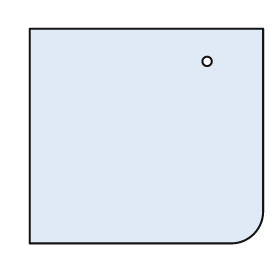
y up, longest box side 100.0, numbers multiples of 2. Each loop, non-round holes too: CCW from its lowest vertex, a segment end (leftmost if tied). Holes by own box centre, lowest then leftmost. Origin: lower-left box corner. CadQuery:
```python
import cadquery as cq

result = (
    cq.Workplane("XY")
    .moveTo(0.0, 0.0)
    .lineTo(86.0, 0.0)
    .threePointArc((96.0, 4.0), (100.0, 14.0))
    .lineTo(100.0, 92.0)
    .lineTo(0.0, 92.0)
    .close()
    .moveTo(76.0, 78.0)
    .circle(2.0)
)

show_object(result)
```